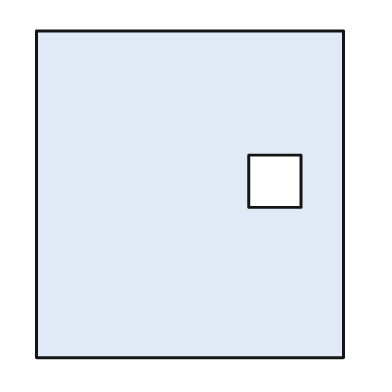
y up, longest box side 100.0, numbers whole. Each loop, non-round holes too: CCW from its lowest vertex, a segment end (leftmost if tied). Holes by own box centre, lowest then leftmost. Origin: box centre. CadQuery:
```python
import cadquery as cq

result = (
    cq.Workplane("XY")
    .moveTo(-47.0, -50.0)
    .lineTo(47.0, -50.0)
    .lineTo(47.0, 50.0)
    .lineTo(-47.0, 50.0)
    .close()
    .moveTo(18.0, -4.0)
    .lineTo(34.0, -4.0)
    .lineTo(34.0, 12.0)
    .lineTo(18.0, 12.0)
    .close()
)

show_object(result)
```